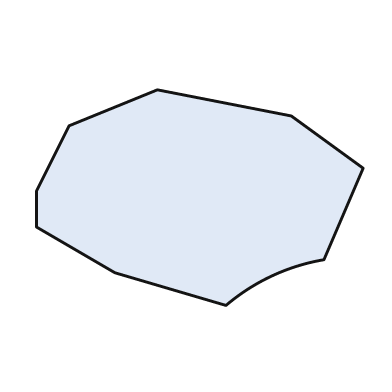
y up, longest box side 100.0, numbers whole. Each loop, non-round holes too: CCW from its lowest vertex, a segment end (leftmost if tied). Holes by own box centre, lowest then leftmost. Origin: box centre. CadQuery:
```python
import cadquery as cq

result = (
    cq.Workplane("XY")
    .moveTo(8.0, -33.0)
    .threePointArc((22.0, -24.0), (38.0, -19.0))
    .lineTo(50.0, 9.0)
    .lineTo(28.0, 25.0)
    .lineTo(-13.0, 33.0)
    .lineTo(-40.0, 22.0)
    .lineTo(-50.0, 2.0)
    .lineTo(-50.0, -9.0)
    .lineTo(-26.0, -23.0)
    .close()
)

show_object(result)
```